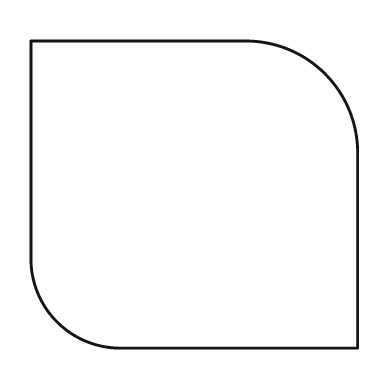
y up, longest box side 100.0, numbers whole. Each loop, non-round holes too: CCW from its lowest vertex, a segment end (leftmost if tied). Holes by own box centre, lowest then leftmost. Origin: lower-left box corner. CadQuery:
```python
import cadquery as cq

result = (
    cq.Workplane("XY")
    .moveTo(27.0, 0.0)
    .lineTo(100.0, 0.0)
    .lineTo(100.0, 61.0)
    .threePointArc((90.0, 84.0), (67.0, 94.0))
    .lineTo(0.0, 94.0)
    .lineTo(0.0, 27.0)
    .threePointArc((8.0, 8.0), (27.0, 0.0))
    .close()
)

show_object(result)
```